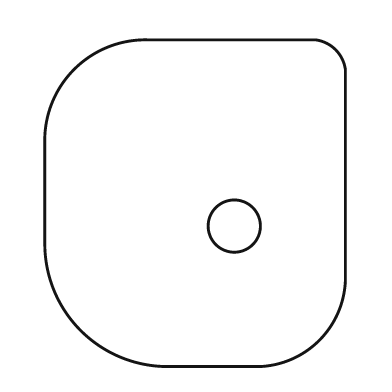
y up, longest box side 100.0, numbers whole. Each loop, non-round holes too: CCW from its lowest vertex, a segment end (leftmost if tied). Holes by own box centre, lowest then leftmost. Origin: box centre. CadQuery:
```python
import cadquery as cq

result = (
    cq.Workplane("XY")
    .moveTo(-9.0, -50.0)
    .lineTo(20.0, -50.0)
    .threePointArc((38.0, -42.0), (46.0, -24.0))
    .lineTo(46.0, 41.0)
    .threePointArc((43.0, 47.0), (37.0, 50.0))
    .lineTo(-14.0, 50.0)
    .threePointArc((-37.0, 41.0), (-46.0, 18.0))
    .lineTo(-46.0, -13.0)
    .threePointArc((-35.0, -39.0), (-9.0, -50.0))
    .close()
    .moveTo(12.0, -7.0)
    .circle(8.0)
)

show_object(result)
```